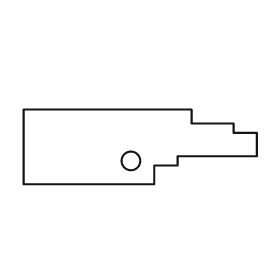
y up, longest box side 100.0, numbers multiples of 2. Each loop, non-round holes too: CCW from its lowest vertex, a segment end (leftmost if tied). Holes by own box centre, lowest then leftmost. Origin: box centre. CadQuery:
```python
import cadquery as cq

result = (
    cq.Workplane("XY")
    .moveTo(-50.0, -16.0)
    .lineTo(6.0, -16.0)
    .lineTo(6.0, -8.0)
    .lineTo(16.0, -8.0)
    .lineTo(16.0, -4.0)
    .lineTo(50.0, -4.0)
    .lineTo(50.0, 6.0)
    .lineTo(40.0, 6.0)
    .lineTo(40.0, 10.0)
    .lineTo(22.0, 10.0)
    .lineTo(22.0, 16.0)
    .lineTo(-50.0, 16.0)
    .close()
    .moveTo(-4.0, -6.0)
    .circle(4.0)
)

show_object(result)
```